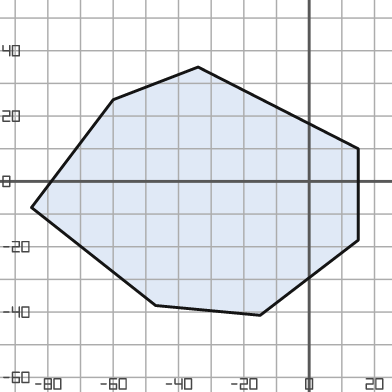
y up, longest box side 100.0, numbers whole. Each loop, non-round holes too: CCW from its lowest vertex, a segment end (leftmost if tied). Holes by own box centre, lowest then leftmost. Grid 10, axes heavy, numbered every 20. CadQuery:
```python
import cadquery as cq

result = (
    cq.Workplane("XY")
    .moveTo(-15.0, -41.0)
    .lineTo(15.0, -18.0)
    .lineTo(15.0, 10.0)
    .lineTo(-34.0, 35.0)
    .lineTo(-60.0, 25.0)
    .lineTo(-85.0, -8.0)
    .lineTo(-47.0, -38.0)
    .close()
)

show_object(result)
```